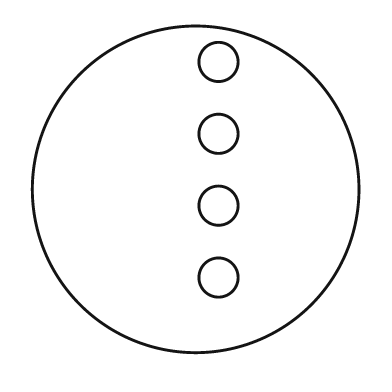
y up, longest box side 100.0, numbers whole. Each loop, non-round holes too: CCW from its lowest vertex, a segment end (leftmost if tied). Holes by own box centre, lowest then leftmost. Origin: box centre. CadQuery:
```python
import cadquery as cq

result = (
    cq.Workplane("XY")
    .moveTo(0.0, 0.0)
    .circle(50.0)
    .moveTo(7.0, -27.0)
    .circle(6.0)
    .moveTo(7.0, -5.0)
    .circle(6.0)
    .moveTo(7.0, 17.0)
    .circle(6.0)
    .moveTo(7.0, 39.0)
    .circle(6.0)
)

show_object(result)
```